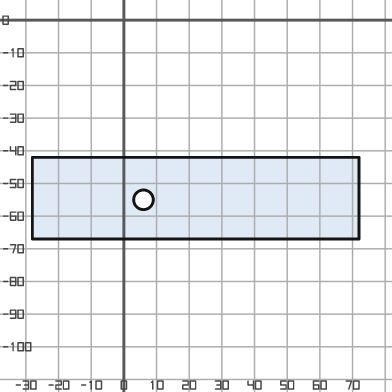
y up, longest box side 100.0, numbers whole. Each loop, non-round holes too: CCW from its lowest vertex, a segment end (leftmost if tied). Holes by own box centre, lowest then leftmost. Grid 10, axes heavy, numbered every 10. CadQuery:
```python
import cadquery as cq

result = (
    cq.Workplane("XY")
    .moveTo(-28.0, -67.0)
    .lineTo(72.0, -67.0)
    .lineTo(72.0, -42.0)
    .lineTo(-28.0, -42.0)
    .close()
    .moveTo(6.0, -55.0)
    .circle(3.0)
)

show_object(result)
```